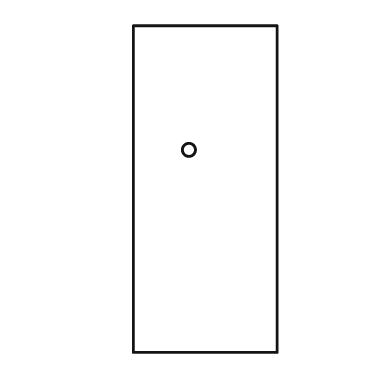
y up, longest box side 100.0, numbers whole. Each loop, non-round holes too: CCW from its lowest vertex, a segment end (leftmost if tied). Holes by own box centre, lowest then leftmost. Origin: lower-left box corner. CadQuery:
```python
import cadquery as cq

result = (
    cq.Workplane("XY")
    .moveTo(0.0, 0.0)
    .lineTo(44.0, 0.0)
    .lineTo(44.0, 100.0)
    .lineTo(0.0, 100.0)
    .close()
    .moveTo(17.0, 62.0)
    .circle(2.0)
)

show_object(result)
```